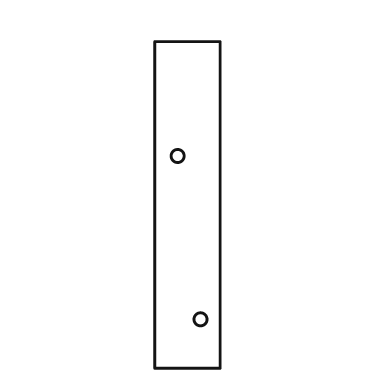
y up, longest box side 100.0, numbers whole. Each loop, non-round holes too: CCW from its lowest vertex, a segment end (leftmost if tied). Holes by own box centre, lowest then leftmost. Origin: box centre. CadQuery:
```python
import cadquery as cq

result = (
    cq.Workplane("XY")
    .moveTo(-10.0, -50.0)
    .lineTo(10.0, -50.0)
    .lineTo(10.0, 50.0)
    .lineTo(-10.0, 50.0)
    .close()
    .moveTo(4.0, -35.0)
    .circle(2.0)
    .moveTo(-3.0, 15.0)
    .circle(2.0)
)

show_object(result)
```